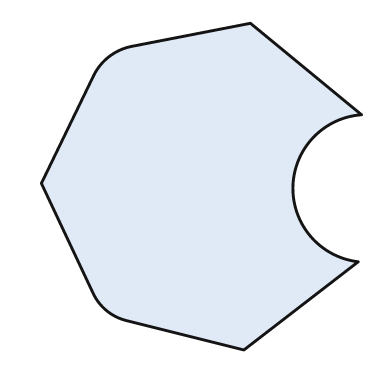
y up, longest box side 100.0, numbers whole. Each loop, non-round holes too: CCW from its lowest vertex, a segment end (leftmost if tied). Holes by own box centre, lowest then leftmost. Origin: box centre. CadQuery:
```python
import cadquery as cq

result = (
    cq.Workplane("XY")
    .moveTo(13.0, -50.0)
    .lineTo(48.0, -23.0)
    .threePointArc((28.0, 0.0), (49.0, 22.0))
    .lineTo(15.0, 50.0)
    .lineTo(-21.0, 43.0)
    .threePointArc((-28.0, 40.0), (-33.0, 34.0))
    .lineTo(-49.0, 1.0)
    .lineTo(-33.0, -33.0)
    .threePointArc((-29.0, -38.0), (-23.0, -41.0))
    .close()
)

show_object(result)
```